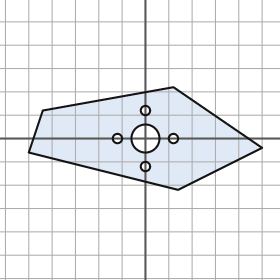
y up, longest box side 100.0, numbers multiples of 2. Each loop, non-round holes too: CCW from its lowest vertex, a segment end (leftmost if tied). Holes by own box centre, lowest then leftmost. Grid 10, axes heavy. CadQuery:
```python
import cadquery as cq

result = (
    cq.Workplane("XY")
    .moveTo(14.0, -22.0)
    .lineTo(50.0, -4.0)
    .lineTo(12.0, 22.0)
    .lineTo(-44.0, 12.0)
    .lineTo(-50.0, -6.0)
    .close()
    .moveTo(0.0, -12.0)
    .circle(2.0)
    .moveTo(-12.0, 0.0)
    .circle(2.0)
    .moveTo(0.0, 0.0)
    .circle(6.0)
    .moveTo(12.0, 0.0)
    .circle(2.0)
    .moveTo(0.0, 12.0)
    .circle(2.0)
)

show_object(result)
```